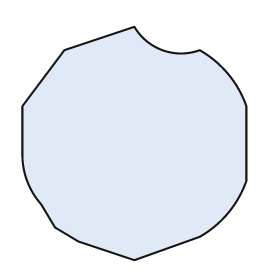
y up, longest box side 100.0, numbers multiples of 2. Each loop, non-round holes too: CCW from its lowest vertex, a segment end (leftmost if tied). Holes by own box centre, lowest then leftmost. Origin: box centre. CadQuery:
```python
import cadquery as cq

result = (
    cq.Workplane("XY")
    .moveTo(0.0, -50.0)
    .lineTo(28.0, -40.0)
    .threePointArc((40.0, -30.0), (48.0, -16.0))
    .lineTo(48.0, 16.0)
    .threePointArc((40.0, 30.0), (28.0, 40.0))
    .threePointArc((12.0, 40.0), (0.0, 50.0))
    .lineTo(-30.0, 40.0)
    .lineTo(-48.0, 16.0)
    .lineTo(-48.0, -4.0)
    .threePointArc((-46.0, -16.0), (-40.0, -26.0))
    .lineTo(-34.0, -36.0)
    .lineTo(-24.0, -42.0)
    .close()
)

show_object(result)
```